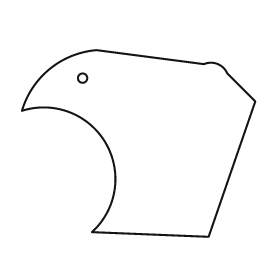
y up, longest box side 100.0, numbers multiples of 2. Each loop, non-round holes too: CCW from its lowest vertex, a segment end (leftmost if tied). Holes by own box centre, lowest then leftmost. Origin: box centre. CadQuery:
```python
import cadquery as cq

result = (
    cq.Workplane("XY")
    .moveTo(30.0, -40.0)
    .lineTo(50.0, 18.0)
    .lineTo(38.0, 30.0)
    .threePointArc((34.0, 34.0), (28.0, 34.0))
    .lineTo(-18.0, 40.0)
    .threePointArc((-38.0, 32.0), (-50.0, 14.0))
    .threePointArc((-14.0, 0.0), (-20.0, -38.0))
    .close()
    .moveTo(-24.0, 28.0)
    .circle(2.0)
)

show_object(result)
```